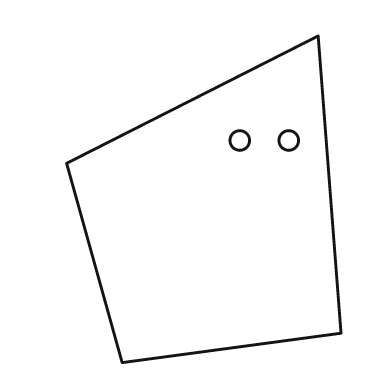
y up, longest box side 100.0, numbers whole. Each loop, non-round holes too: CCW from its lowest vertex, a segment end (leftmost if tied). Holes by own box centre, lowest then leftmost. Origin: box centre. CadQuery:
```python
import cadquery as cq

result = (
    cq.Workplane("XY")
    .moveTo(-25.0, -50.0)
    .lineTo(42.0, -41.0)
    .lineTo(35.0, 50.0)
    .lineTo(-42.0, 11.0)
    .close()
    .moveTo(11.0, 18.0)
    .circle(3.0)
    .moveTo(26.0, 18.0)
    .circle(3.0)
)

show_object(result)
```